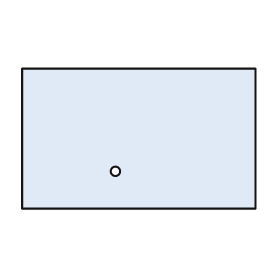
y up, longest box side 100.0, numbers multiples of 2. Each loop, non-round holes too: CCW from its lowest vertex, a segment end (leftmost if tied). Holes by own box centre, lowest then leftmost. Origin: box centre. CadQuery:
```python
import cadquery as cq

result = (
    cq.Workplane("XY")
    .moveTo(-50.0, -30.0)
    .lineTo(50.0, -30.0)
    .lineTo(50.0, 30.0)
    .lineTo(-50.0, 30.0)
    .close()
    .moveTo(-10.0, -14.0)
    .circle(2.0)
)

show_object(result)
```